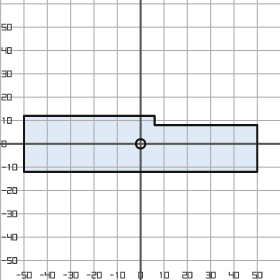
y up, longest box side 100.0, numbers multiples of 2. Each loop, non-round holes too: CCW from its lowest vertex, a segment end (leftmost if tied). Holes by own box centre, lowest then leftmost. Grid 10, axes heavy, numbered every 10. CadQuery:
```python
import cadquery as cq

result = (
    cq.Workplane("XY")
    .moveTo(-50.0, -12.0)
    .lineTo(50.0, -12.0)
    .lineTo(50.0, 8.0)
    .lineTo(6.0, 8.0)
    .lineTo(6.0, 12.0)
    .lineTo(-50.0, 12.0)
    .close()
    .moveTo(0.0, 0.0)
    .circle(2.0)
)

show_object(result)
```